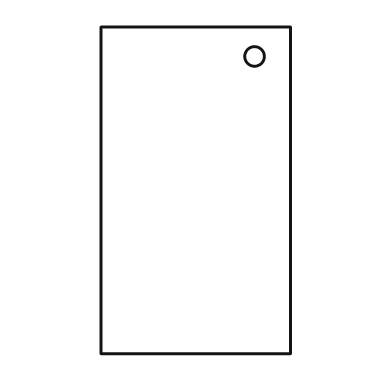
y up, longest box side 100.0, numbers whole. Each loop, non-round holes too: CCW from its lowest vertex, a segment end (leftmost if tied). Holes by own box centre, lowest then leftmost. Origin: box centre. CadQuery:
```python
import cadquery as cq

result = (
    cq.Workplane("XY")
    .moveTo(-29.0, -50.0)
    .lineTo(29.0, -50.0)
    .lineTo(29.0, 50.0)
    .lineTo(-29.0, 50.0)
    .close()
    .moveTo(18.0, 41.0)
    .circle(3.0)
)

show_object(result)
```